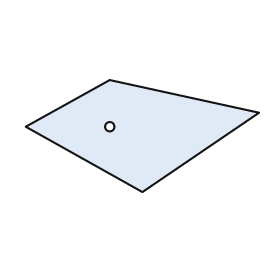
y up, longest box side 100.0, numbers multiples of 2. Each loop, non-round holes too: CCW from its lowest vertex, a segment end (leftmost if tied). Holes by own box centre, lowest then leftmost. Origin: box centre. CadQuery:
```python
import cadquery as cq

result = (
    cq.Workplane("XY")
    .moveTo(0.0, -24.0)
    .lineTo(50.0, 10.0)
    .lineTo(-14.0, 24.0)
    .lineTo(-50.0, 4.0)
    .close()
    .moveTo(-14.0, 4.0)
    .circle(2.0)
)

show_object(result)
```